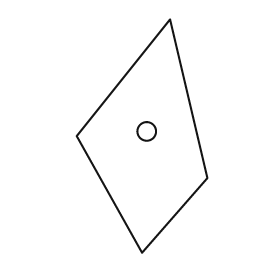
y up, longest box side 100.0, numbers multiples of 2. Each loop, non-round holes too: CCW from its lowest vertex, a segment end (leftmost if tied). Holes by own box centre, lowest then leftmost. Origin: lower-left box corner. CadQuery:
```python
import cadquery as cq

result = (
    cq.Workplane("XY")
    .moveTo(28.0, 0.0)
    .lineTo(56.0, 32.0)
    .lineTo(40.0, 100.0)
    .lineTo(0.0, 50.0)
    .close()
    .moveTo(30.0, 52.0)
    .circle(4.0)
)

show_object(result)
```